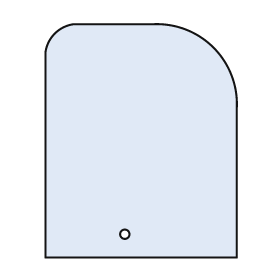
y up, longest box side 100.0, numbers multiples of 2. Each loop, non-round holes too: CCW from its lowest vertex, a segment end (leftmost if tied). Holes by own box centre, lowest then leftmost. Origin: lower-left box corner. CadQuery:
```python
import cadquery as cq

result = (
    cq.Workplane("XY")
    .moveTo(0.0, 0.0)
    .lineTo(82.0, 0.0)
    .lineTo(82.0, 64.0)
    .threePointArc((72.0, 90.0), (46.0, 100.0))
    .lineTo(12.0, 100.0)
    .threePointArc((4.0, 96.0), (0.0, 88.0))
    .close()
    .moveTo(34.0, 10.0)
    .circle(2.0)
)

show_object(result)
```